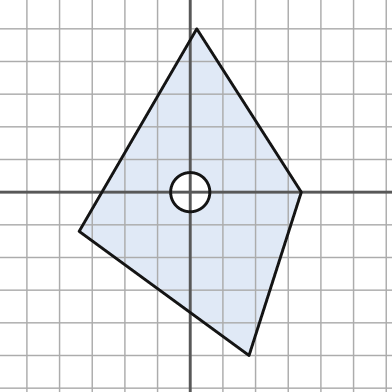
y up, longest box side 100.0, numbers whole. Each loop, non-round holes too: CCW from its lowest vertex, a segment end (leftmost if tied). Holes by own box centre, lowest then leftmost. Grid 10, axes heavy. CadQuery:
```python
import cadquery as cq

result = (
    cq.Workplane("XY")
    .moveTo(18.0, -50.0)
    .lineTo(34.0, 0.0)
    .lineTo(2.0, 50.0)
    .lineTo(-34.0, -12.0)
    .close()
    .moveTo(0.0, 0.0)
    .circle(6.0)
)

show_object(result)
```